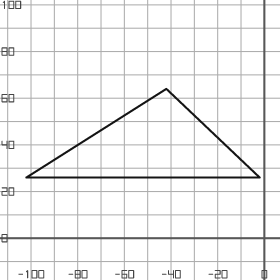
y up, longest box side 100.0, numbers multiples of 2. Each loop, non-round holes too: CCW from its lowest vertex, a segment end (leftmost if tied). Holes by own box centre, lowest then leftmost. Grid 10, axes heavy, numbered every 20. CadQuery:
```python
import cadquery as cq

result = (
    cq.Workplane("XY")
    .moveTo(-102.0, 26.0)
    .lineTo(-2.0, 26.0)
    .lineTo(-42.0, 64.0)
    .close()
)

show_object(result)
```